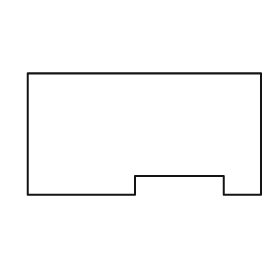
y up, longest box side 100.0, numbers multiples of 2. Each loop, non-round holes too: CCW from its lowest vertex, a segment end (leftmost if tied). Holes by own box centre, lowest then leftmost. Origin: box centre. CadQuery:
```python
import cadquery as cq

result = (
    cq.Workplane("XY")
    .moveTo(-50.0, -26.0)
    .lineTo(-4.0, -26.0)
    .lineTo(-4.0, -18.0)
    .lineTo(34.0, -18.0)
    .lineTo(34.0, -26.0)
    .lineTo(50.0, -26.0)
    .lineTo(50.0, 26.0)
    .lineTo(-50.0, 26.0)
    .close()
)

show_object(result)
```